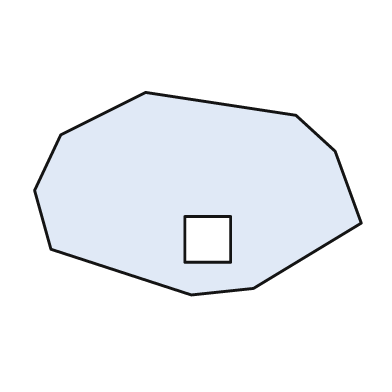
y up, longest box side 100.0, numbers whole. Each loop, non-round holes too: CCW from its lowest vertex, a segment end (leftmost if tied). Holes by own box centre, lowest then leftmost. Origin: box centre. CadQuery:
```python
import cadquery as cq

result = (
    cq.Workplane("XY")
    .moveTo(-2.0, -31.0)
    .lineTo(17.0, -29.0)
    .lineTo(50.0, -9.0)
    .lineTo(42.0, 13.0)
    .lineTo(30.0, 24.0)
    .lineTo(-16.0, 31.0)
    .lineTo(-42.0, 18.0)
    .lineTo(-50.0, 1.0)
    .lineTo(-45.0, -17.0)
    .close()
    .moveTo(-4.0, -21.0)
    .lineTo(10.0, -21.0)
    .lineTo(10.0, -7.0)
    .lineTo(-4.0, -7.0)
    .close()
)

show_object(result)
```